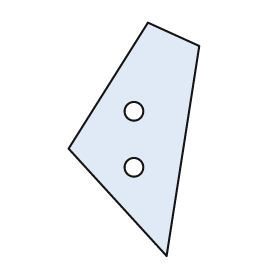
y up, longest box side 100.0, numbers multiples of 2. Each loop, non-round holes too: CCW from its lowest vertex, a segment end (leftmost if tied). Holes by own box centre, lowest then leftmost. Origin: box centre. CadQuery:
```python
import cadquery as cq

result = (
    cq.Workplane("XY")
    .moveTo(14.0, -50.0)
    .lineTo(28.0, 40.0)
    .lineTo(6.0, 50.0)
    .lineTo(-28.0, -4.0)
    .close()
    .moveTo(0.0, -12.0)
    .circle(4.0)
    .moveTo(0.0, 12.0)
    .circle(4.0)
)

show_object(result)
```